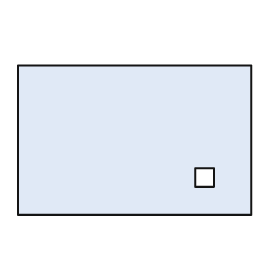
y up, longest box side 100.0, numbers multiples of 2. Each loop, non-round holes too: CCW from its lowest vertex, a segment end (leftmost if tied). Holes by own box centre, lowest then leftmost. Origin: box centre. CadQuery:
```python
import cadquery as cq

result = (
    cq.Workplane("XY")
    .moveTo(-50.0, -32.0)
    .lineTo(50.0, -32.0)
    .lineTo(50.0, 32.0)
    .lineTo(-50.0, 32.0)
    .close()
    .moveTo(26.0, -20.0)
    .lineTo(34.0, -20.0)
    .lineTo(34.0, -12.0)
    .lineTo(26.0, -12.0)
    .close()
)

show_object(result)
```